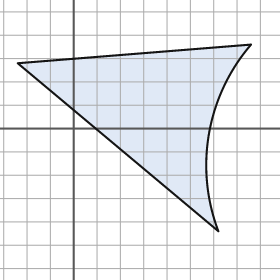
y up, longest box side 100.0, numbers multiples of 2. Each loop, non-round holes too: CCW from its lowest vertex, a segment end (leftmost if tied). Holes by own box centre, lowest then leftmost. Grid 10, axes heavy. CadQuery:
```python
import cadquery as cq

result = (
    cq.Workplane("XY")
    .moveTo(62.0, -44.0)
    .threePointArc((58.0, -2.0), (76.0, 36.0))
    .lineTo(-24.0, 28.0)
    .close()
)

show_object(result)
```